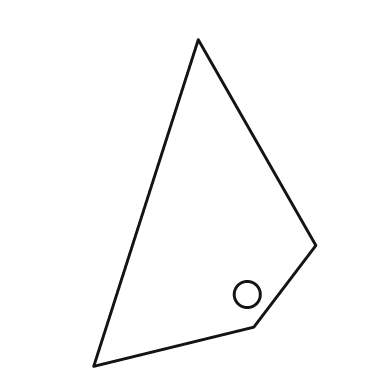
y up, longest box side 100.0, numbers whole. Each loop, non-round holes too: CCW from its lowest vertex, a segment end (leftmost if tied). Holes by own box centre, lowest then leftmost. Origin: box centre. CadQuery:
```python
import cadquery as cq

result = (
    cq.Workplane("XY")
    .moveTo(-34.0, -50.0)
    .lineTo(15.0, -38.0)
    .lineTo(34.0, -13.0)
    .lineTo(-2.0, 50.0)
    .close()
    .moveTo(13.0, -28.0)
    .circle(4.0)
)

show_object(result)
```